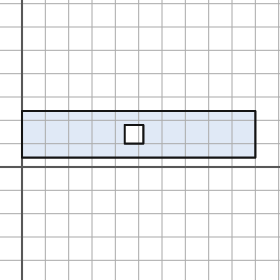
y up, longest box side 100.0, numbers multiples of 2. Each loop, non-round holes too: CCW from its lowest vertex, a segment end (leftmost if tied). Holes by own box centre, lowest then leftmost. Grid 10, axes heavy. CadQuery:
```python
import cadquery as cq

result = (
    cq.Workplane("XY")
    .moveTo(0.0, 4.0)
    .lineTo(100.0, 4.0)
    .lineTo(100.0, 24.0)
    .lineTo(0.0, 24.0)
    .close()
    .moveTo(44.0, 10.0)
    .lineTo(52.0, 10.0)
    .lineTo(52.0, 18.0)
    .lineTo(44.0, 18.0)
    .close()
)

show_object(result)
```